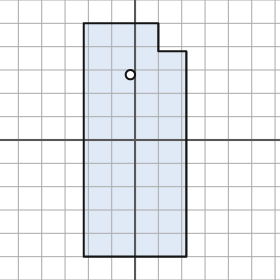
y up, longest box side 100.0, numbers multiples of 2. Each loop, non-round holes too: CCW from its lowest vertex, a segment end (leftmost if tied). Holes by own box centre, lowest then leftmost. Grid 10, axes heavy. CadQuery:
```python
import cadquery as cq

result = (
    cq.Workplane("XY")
    .moveTo(-22.0, -50.0)
    .lineTo(22.0, -50.0)
    .lineTo(22.0, 38.0)
    .lineTo(10.0, 38.0)
    .lineTo(10.0, 50.0)
    .lineTo(-22.0, 50.0)
    .close()
    .moveTo(-2.0, 28.0)
    .circle(2.0)
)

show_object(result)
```